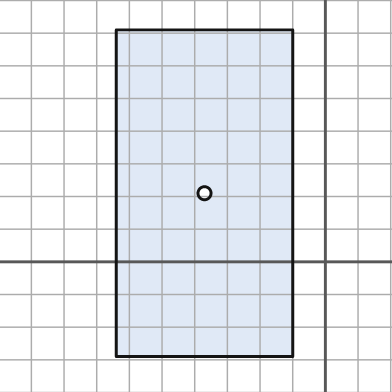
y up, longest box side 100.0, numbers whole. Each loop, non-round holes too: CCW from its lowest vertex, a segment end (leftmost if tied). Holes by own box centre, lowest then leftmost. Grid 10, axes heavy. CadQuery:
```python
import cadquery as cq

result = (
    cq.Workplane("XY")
    .moveTo(-64.0, -29.0)
    .lineTo(-10.0, -29.0)
    .lineTo(-10.0, 71.0)
    .lineTo(-64.0, 71.0)
    .close()
    .moveTo(-37.0, 21.0)
    .circle(2.0)
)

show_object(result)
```